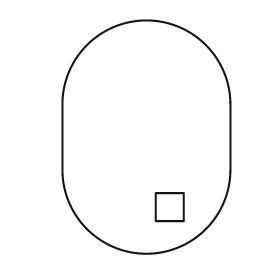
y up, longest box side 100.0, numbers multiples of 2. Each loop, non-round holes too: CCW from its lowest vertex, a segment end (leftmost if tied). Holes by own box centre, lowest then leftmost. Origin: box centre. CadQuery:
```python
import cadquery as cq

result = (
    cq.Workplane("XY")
    .moveTo(-36.0, -14.0)
    .threePointArc((0.0, -50.0), (36.0, -14.0))
    .lineTo(36.0, 14.0)
    .threePointArc((0.0, 50.0), (-36.0, 14.0))
    .close()
    .moveTo(4.0, -36.0)
    .lineTo(16.0, -36.0)
    .lineTo(16.0, -24.0)
    .lineTo(4.0, -24.0)
    .close()
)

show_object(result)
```